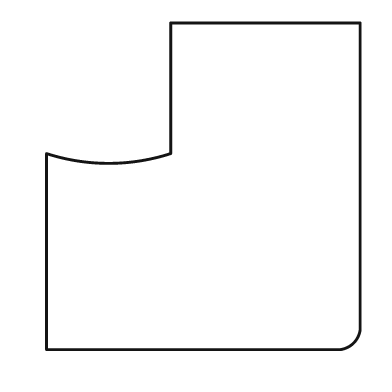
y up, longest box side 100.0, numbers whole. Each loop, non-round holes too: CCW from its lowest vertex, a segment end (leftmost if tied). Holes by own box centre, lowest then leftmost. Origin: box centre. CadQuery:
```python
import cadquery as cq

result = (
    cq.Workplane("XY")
    .moveTo(-48.0, -50.0)
    .lineTo(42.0, -50.0)
    .threePointArc((46.0, -48.0), (48.0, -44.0))
    .lineTo(48.0, 50.0)
    .lineTo(-10.0, 50.0)
    .lineTo(-10.0, 10.0)
    .threePointArc((-29.0, 7.0), (-48.0, 10.0))
    .close()
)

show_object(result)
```